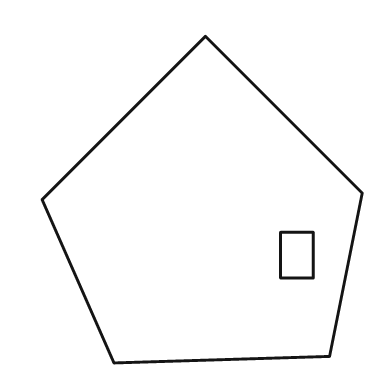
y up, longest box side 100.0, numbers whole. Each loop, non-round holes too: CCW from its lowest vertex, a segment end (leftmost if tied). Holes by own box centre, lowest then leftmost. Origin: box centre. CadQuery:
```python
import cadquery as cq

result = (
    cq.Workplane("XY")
    .moveTo(-27.0, -50.0)
    .lineTo(39.0, -48.0)
    .lineTo(49.0, 2.0)
    .lineTo(1.0, 50.0)
    .lineTo(-49.0, 0.0)
    .close()
    .moveTo(24.0, -24.0)
    .lineTo(34.0, -24.0)
    .lineTo(34.0, -10.0)
    .lineTo(24.0, -10.0)
    .close()
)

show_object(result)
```